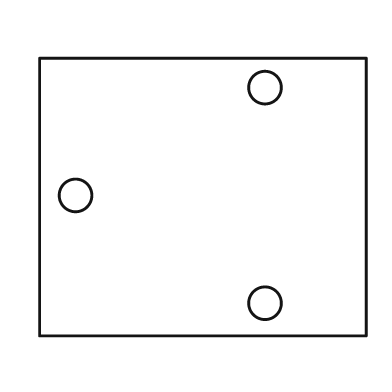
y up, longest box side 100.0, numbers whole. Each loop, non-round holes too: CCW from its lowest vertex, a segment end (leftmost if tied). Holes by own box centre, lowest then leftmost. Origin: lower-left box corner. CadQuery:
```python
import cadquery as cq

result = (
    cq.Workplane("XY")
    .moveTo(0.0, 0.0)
    .lineTo(100.0, 0.0)
    .lineTo(100.0, 85.0)
    .lineTo(0.0, 85.0)
    .close()
    .moveTo(69.0, 10.0)
    .circle(5.0)
    .moveTo(11.0, 43.0)
    .circle(5.0)
    .moveTo(69.0, 76.0)
    .circle(5.0)
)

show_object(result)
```